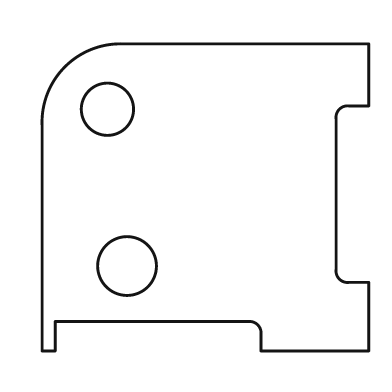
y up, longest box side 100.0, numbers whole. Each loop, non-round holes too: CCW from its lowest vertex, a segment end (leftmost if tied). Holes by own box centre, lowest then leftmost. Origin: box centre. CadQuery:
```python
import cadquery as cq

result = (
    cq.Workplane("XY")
    .moveTo(-50.0, -47.0)
    .lineTo(-46.0, -47.0)
    .lineTo(-46.0, -38.0)
    .lineTo(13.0, -38.0)
    .threePointArc((16.0, -39.0), (17.0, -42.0))
    .lineTo(17.0, -47.0)
    .lineTo(50.0, -47.0)
    .lineTo(50.0, -26.0)
    .lineTo(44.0, -26.0)
    .threePointArc((41.0, -25.0), (40.0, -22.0))
    .lineTo(40.0, 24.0)
    .threePointArc((41.0, 27.0), (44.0, 28.0))
    .lineTo(50.0, 28.0)
    .lineTo(50.0, 47.0)
    .lineTo(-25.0, 47.0)
    .threePointArc((-43.0, 40.0), (-50.0, 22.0))
    .close()
    .moveTo(-24.0, -21.0)
    .circle(9.0)
    .moveTo(-30.0, 27.0)
    .circle(8.0)
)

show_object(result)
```